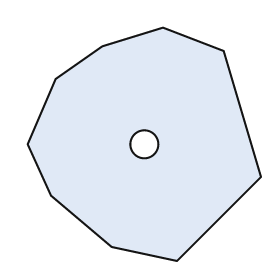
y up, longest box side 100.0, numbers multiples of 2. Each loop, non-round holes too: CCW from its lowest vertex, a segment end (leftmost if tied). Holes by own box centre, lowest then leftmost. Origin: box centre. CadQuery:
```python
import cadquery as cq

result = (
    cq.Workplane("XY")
    .moveTo(14.0, -50.0)
    .lineTo(50.0, -14.0)
    .lineTo(34.0, 40.0)
    .lineTo(8.0, 50.0)
    .lineTo(-18.0, 42.0)
    .lineTo(-38.0, 28.0)
    .lineTo(-50.0, 0.0)
    .lineTo(-40.0, -22.0)
    .lineTo(-14.0, -44.0)
    .close()
    .moveTo(0.0, 0.0)
    .circle(6.0)
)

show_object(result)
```